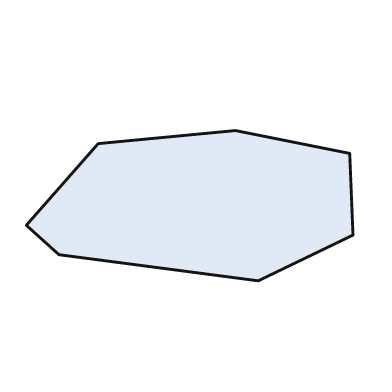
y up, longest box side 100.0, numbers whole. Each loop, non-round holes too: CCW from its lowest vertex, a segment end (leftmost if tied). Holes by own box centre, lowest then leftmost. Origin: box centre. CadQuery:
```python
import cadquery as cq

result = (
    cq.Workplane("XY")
    .moveTo(21.0, -23.0)
    .lineTo(50.0, -9.0)
    .lineTo(49.0, 16.0)
    .lineTo(14.0, 23.0)
    .lineTo(-28.0, 19.0)
    .lineTo(-50.0, -6.0)
    .lineTo(-40.0, -15.0)
    .close()
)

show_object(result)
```